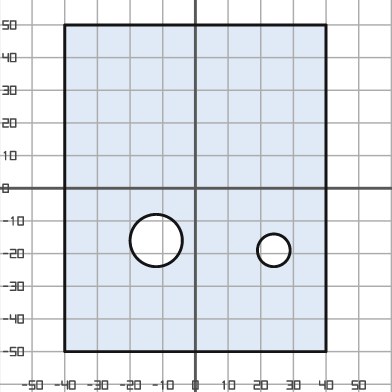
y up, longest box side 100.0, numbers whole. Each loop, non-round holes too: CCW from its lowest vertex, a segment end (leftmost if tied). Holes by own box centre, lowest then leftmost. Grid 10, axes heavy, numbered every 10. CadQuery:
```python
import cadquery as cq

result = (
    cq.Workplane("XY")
    .moveTo(-40.0, -50.0)
    .lineTo(40.0, -50.0)
    .lineTo(40.0, 50.0)
    .lineTo(-40.0, 50.0)
    .close()
    .moveTo(24.0, -19.0)
    .circle(5.0)
    .moveTo(-12.0, -16.0)
    .circle(8.0)
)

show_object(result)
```